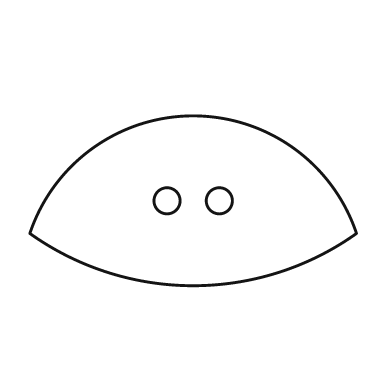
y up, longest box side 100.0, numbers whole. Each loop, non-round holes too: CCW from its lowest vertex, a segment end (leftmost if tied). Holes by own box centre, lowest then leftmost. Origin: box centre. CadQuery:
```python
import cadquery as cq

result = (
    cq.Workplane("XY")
    .moveTo(-50.0, -10.0)
    .threePointArc((0.0, -26.0), (50.0, -10.0))
    .threePointArc((0.0, 26.0), (-50.0, -10.0))
    .close()
    .moveTo(-8.0, 0.0)
    .circle(4.0)
    .moveTo(8.0, 0.0)
    .circle(4.0)
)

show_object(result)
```